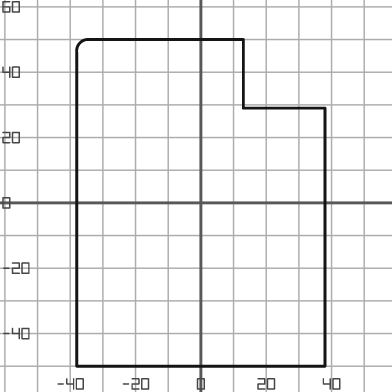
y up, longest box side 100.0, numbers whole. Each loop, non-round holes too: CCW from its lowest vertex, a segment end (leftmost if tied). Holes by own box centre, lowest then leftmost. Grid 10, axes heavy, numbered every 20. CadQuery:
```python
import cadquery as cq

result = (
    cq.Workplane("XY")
    .moveTo(-38.0, -50.0)
    .lineTo(38.0, -50.0)
    .lineTo(38.0, 29.0)
    .lineTo(13.0, 29.0)
    .lineTo(13.0, 50.0)
    .lineTo(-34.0, 50.0)
    .threePointArc((-37.0, 49.0), (-38.0, 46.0))
    .close()
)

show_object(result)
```